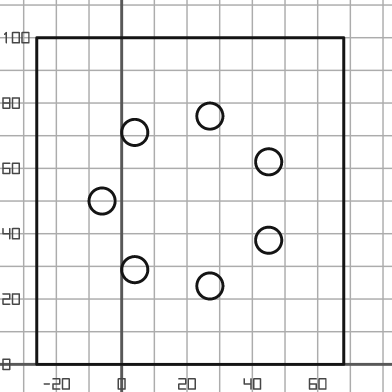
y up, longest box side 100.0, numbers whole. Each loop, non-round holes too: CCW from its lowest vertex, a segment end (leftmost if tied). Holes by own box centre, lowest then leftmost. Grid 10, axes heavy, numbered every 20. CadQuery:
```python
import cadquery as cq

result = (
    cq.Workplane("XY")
    .moveTo(-26.0, 0.0)
    .lineTo(68.0, 0.0)
    .lineTo(68.0, 100.0)
    .lineTo(-26.0, 100.0)
    .close()
    .moveTo(27.0, 24.0)
    .circle(4.0)
    .moveTo(4.0, 29.0)
    .circle(4.0)
    .moveTo(45.0, 38.0)
    .circle(4.0)
    .moveTo(-6.0, 50.0)
    .circle(4.0)
    .moveTo(45.0, 62.0)
    .circle(4.0)
    .moveTo(4.0, 71.0)
    .circle(4.0)
    .moveTo(27.0, 76.0)
    .circle(4.0)
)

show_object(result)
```